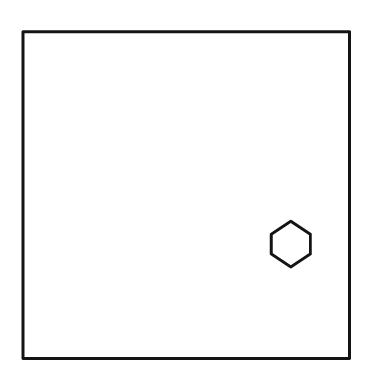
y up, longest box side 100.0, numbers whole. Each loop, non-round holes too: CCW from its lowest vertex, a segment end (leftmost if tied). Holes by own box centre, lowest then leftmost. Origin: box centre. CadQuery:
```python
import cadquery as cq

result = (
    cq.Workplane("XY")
    .moveTo(-50.0, -50.0)
    .lineTo(50.0, -50.0)
    .lineTo(50.0, 50.0)
    .lineTo(-50.0, 50.0)
    .close()
    .moveTo(32.0, -22.0)
    .lineTo(38.0, -18.0)
    .lineTo(38.0, -12.0)
    .lineTo(32.0, -8.0)
    .lineTo(26.0, -12.0)
    .lineTo(26.0, -18.0)
    .close()
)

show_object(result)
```